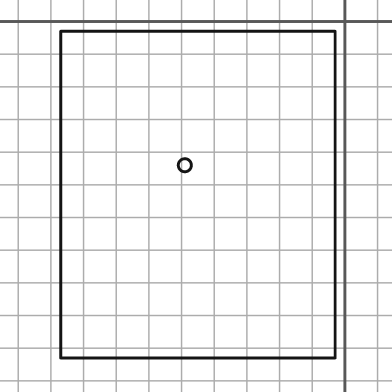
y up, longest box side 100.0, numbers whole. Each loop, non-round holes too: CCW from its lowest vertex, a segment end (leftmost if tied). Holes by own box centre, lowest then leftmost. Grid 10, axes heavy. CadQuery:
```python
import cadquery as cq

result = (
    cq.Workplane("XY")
    .moveTo(-87.0, -103.0)
    .lineTo(-3.0, -103.0)
    .lineTo(-3.0, -3.0)
    .lineTo(-87.0, -3.0)
    .close()
    .moveTo(-49.0, -44.0)
    .circle(2.0)
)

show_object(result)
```